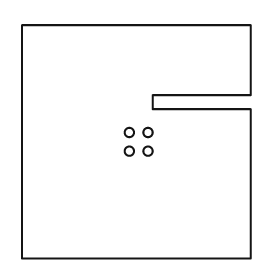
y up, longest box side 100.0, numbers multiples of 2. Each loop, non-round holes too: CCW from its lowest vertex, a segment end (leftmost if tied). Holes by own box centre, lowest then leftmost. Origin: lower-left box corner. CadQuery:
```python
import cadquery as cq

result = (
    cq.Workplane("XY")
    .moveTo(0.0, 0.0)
    .lineTo(98.0, 0.0)
    .lineTo(98.0, 64.0)
    .lineTo(56.0, 64.0)
    .lineTo(56.0, 70.0)
    .lineTo(98.0, 70.0)
    .lineTo(98.0, 100.0)
    .lineTo(0.0, 100.0)
    .close()
    .moveTo(46.0, 46.0)
    .circle(2.0)
    .moveTo(54.0, 46.0)
    .circle(2.0)
    .moveTo(46.0, 54.0)
    .circle(2.0)
    .moveTo(54.0, 54.0)
    .circle(2.0)
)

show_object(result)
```